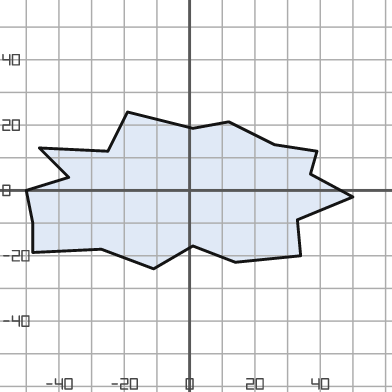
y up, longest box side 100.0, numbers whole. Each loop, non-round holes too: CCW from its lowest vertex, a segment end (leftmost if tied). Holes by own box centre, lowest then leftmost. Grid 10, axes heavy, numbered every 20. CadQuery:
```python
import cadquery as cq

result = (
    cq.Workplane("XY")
    .moveTo(-11.0, -24.0)
    .lineTo(1.0, -17.0)
    .lineTo(14.0, -22.0)
    .lineTo(34.0, -20.0)
    .lineTo(33.0, -9.0)
    .lineTo(50.0, -2.0)
    .lineTo(37.0, 5.0)
    .lineTo(39.0, 12.0)
    .lineTo(26.0, 14.0)
    .lineTo(12.0, 21.0)
    .lineTo(1.0, 19.0)
    .lineTo(-19.0, 24.0)
    .lineTo(-25.0, 12.0)
    .lineTo(-46.0, 13.0)
    .lineTo(-37.0, 4.0)
    .lineTo(-50.0, 0.0)
    .lineTo(-48.0, -10.0)
    .lineTo(-48.0, -19.0)
    .lineTo(-27.0, -18.0)
    .close()
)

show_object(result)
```